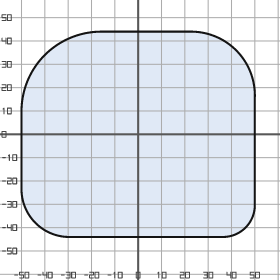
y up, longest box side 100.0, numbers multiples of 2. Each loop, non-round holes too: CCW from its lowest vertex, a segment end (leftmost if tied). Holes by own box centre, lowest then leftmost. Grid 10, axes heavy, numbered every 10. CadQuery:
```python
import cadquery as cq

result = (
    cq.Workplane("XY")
    .moveTo(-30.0, -44.0)
    .lineTo(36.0, -44.0)
    .threePointArc((46.0, -40.0), (50.0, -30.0))
    .lineTo(50.0, 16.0)
    .threePointArc((42.0, 36.0), (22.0, 44.0))
    .lineTo(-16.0, 44.0)
    .threePointArc((-40.0, 34.0), (-50.0, 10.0))
    .lineTo(-50.0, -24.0)
    .threePointArc((-44.0, -38.0), (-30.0, -44.0))
    .close()
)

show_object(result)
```